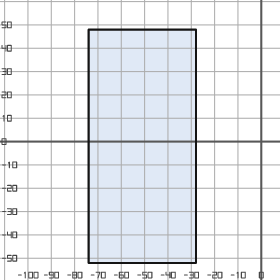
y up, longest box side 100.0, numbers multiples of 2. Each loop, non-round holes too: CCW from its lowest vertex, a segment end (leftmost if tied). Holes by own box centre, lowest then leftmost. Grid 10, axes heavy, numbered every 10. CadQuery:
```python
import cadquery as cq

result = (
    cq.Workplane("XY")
    .moveTo(-74.0, -52.0)
    .lineTo(-28.0, -52.0)
    .lineTo(-28.0, 48.0)
    .lineTo(-74.0, 48.0)
    .close()
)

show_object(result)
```